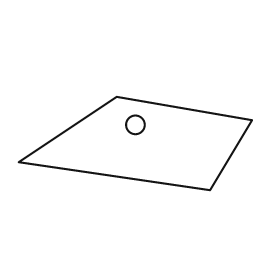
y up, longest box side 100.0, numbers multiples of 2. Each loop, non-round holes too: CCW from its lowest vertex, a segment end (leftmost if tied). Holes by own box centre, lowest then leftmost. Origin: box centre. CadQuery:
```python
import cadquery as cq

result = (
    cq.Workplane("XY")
    .moveTo(32.0, -20.0)
    .lineTo(50.0, 10.0)
    .lineTo(-8.0, 20.0)
    .lineTo(-50.0, -8.0)
    .close()
    .moveTo(0.0, 8.0)
    .circle(4.0)
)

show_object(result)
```